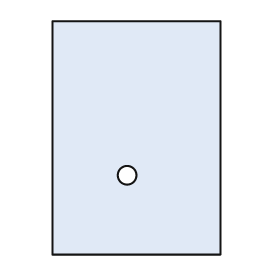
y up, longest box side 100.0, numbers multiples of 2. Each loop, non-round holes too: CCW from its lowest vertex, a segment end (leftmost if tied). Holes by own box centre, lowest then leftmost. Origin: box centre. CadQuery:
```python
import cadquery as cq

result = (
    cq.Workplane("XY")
    .moveTo(-36.0, -50.0)
    .lineTo(36.0, -50.0)
    .lineTo(36.0, 50.0)
    .lineTo(-36.0, 50.0)
    .close()
    .moveTo(-4.0, -16.0)
    .circle(4.0)
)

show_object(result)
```